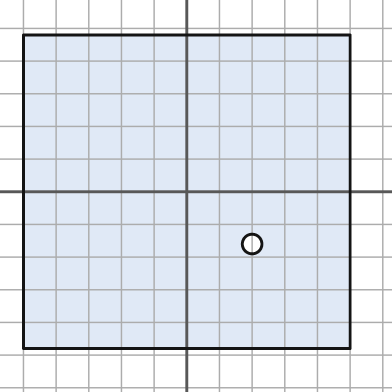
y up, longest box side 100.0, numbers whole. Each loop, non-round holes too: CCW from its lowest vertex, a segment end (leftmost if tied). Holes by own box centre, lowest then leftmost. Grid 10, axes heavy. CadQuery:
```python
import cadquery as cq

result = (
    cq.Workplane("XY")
    .moveTo(-50.0, -48.0)
    .lineTo(50.0, -48.0)
    .lineTo(50.0, 48.0)
    .lineTo(-50.0, 48.0)
    .close()
    .moveTo(20.0, -16.0)
    .circle(3.0)
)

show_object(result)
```